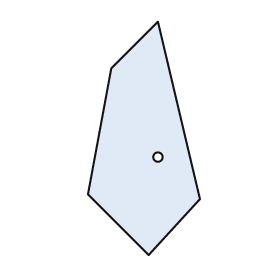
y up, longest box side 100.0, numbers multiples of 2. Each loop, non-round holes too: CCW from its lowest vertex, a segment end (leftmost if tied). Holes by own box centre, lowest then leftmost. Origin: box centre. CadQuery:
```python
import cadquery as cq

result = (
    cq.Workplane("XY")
    .moveTo(2.0, -50.0)
    .lineTo(24.0, -26.0)
    .lineTo(6.0, 50.0)
    .lineTo(-14.0, 30.0)
    .lineTo(-24.0, -24.0)
    .close()
    .moveTo(6.0, -8.0)
    .circle(2.0)
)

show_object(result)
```